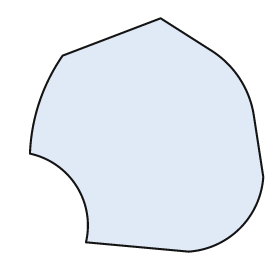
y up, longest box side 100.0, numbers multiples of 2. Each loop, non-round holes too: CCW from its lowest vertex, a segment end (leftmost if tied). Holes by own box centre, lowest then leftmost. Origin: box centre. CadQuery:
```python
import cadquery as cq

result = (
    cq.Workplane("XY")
    .moveTo(18.0, -50.0)
    .threePointArc((40.0, -40.0), (50.0, -18.0))
    .lineTo(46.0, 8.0)
    .threePointArc((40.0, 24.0), (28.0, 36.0))
    .lineTo(6.0, 50.0)
    .lineTo(-36.0, 34.0)
    .threePointArc((-46.0, 14.0), (-50.0, -8.0))
    .threePointArc((-30.0, -22.0), (-26.0, -46.0))
    .close()
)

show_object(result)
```